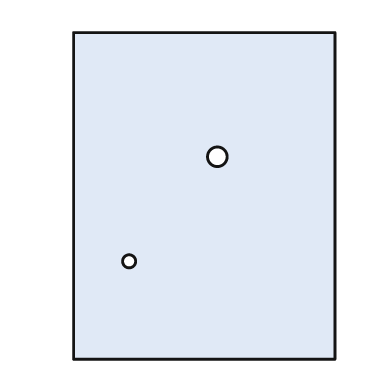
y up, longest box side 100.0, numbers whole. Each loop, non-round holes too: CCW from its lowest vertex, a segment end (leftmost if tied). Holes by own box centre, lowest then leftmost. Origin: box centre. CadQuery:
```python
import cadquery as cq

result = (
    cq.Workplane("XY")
    .moveTo(-40.0, -50.0)
    .lineTo(40.0, -50.0)
    .lineTo(40.0, 50.0)
    .lineTo(-40.0, 50.0)
    .close()
    .moveTo(-23.0, -20.0)
    .circle(2.0)
    .moveTo(4.0, 12.0)
    .circle(3.0)
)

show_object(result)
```